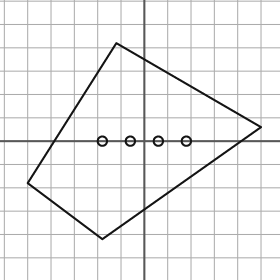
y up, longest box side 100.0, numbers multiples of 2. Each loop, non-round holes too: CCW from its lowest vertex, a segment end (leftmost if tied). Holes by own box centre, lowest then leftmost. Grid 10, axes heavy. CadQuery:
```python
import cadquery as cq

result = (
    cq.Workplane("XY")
    .moveTo(-18.0, -42.0)
    .lineTo(50.0, 6.0)
    .lineTo(-12.0, 42.0)
    .lineTo(-50.0, -18.0)
    .close()
    .moveTo(-18.0, 0.0)
    .circle(2.0)
    .moveTo(-6.0, 0.0)
    .circle(2.0)
    .moveTo(6.0, 0.0)
    .circle(2.0)
    .moveTo(18.0, 0.0)
    .circle(2.0)
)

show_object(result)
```